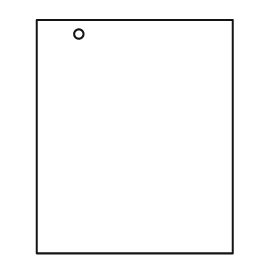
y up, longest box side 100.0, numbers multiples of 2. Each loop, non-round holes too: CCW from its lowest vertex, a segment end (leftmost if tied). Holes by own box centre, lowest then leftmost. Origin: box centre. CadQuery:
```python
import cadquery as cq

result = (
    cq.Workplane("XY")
    .moveTo(-42.0, -50.0)
    .lineTo(42.0, -50.0)
    .lineTo(42.0, 50.0)
    .lineTo(-42.0, 50.0)
    .close()
    .moveTo(-24.0, 44.0)
    .circle(2.0)
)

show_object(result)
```